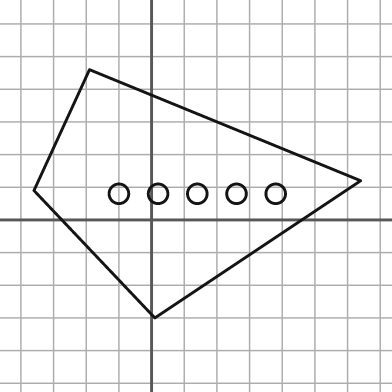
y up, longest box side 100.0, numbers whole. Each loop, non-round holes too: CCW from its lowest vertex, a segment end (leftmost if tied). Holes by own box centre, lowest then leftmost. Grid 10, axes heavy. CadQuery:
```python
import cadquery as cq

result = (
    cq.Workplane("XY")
    .moveTo(1.0, -30.0)
    .lineTo(64.0, 12.0)
    .lineTo(-19.0, 46.0)
    .lineTo(-36.0, 9.0)
    .close()
    .moveTo(-10.0, 8.0)
    .circle(3.0)
    .moveTo(2.0, 8.0)
    .circle(3.0)
    .moveTo(14.0, 8.0)
    .circle(3.0)
    .moveTo(26.0, 8.0)
    .circle(3.0)
    .moveTo(38.0, 8.0)
    .circle(3.0)
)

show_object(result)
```